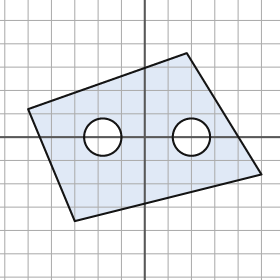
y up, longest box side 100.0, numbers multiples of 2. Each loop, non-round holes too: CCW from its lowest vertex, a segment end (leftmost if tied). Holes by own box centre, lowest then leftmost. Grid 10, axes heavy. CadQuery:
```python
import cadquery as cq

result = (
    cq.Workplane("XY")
    .moveTo(-30.0, -36.0)
    .lineTo(50.0, -16.0)
    .lineTo(18.0, 36.0)
    .lineTo(-50.0, 12.0)
    .close()
    .moveTo(-18.0, 0.0)
    .circle(8.0)
    .moveTo(20.0, 0.0)
    .circle(8.0)
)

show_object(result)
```